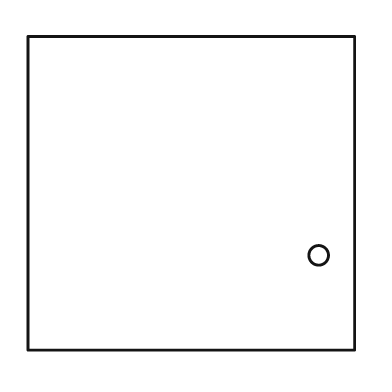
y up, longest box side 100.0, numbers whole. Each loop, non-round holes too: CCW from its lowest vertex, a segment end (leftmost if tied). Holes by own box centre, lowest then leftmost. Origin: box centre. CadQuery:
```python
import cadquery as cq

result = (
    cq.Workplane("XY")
    .moveTo(-50.0, -48.0)
    .lineTo(50.0, -48.0)
    .lineTo(50.0, 48.0)
    .lineTo(-50.0, 48.0)
    .close()
    .moveTo(39.0, -19.0)
    .circle(3.0)
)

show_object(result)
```